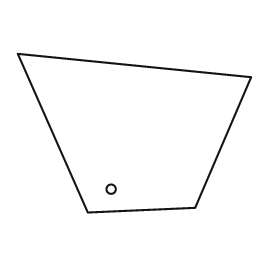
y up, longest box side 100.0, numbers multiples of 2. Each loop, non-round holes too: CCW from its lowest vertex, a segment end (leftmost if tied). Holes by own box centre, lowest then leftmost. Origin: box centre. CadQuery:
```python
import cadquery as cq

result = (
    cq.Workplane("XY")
    .moveTo(-20.0, -34.0)
    .lineTo(26.0, -32.0)
    .lineTo(50.0, 24.0)
    .lineTo(-50.0, 34.0)
    .close()
    .moveTo(-10.0, -24.0)
    .circle(2.0)
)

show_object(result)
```